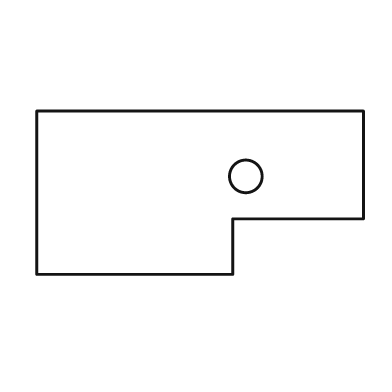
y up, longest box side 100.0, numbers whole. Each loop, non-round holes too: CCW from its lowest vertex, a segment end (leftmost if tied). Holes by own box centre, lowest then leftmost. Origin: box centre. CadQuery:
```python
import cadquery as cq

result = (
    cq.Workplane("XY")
    .moveTo(-50.0, -25.0)
    .lineTo(10.0, -25.0)
    .lineTo(10.0, -8.0)
    .lineTo(50.0, -8.0)
    .lineTo(50.0, 25.0)
    .lineTo(-50.0, 25.0)
    .close()
    .moveTo(14.0, 5.0)
    .circle(5.0)
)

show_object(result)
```